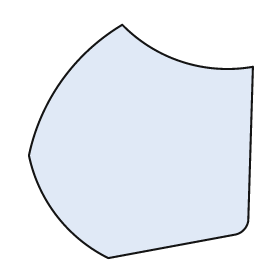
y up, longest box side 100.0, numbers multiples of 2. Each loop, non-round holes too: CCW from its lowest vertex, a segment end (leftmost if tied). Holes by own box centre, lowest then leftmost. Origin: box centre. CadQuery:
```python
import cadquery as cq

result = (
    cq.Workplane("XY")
    .moveTo(-14.0, -50.0)
    .lineTo(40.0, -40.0)
    .threePointArc((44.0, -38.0), (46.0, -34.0))
    .lineTo(48.0, 32.0)
    .threePointArc((18.0, 34.0), (-8.0, 50.0))
    .threePointArc((-34.0, 26.0), (-48.0, -6.0))
    .threePointArc((-36.0, -32.0), (-14.0, -50.0))
    .close()
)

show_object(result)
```